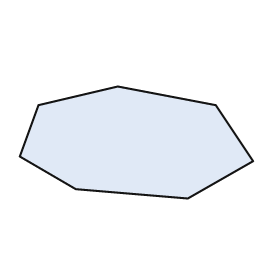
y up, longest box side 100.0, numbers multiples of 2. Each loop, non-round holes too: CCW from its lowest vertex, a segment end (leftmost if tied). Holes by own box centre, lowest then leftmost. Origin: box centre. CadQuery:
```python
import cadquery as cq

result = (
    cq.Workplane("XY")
    .moveTo(22.0, -24.0)
    .lineTo(50.0, -8.0)
    .lineTo(34.0, 16.0)
    .lineTo(-8.0, 24.0)
    .lineTo(-42.0, 16.0)
    .lineTo(-50.0, -6.0)
    .lineTo(-26.0, -20.0)
    .close()
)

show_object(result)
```